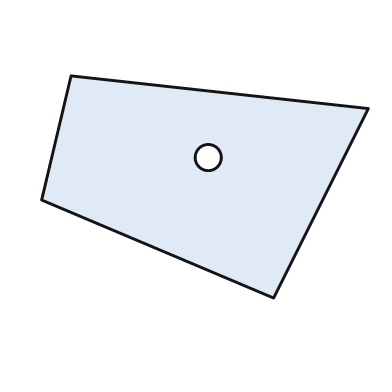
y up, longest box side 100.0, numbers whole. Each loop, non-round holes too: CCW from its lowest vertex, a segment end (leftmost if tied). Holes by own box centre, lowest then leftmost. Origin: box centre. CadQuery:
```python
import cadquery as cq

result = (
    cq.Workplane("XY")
    .moveTo(21.0, -34.0)
    .lineTo(50.0, 24.0)
    .lineTo(-41.0, 34.0)
    .lineTo(-50.0, -4.0)
    .close()
    .moveTo(1.0, 9.0)
    .circle(4.0)
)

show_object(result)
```